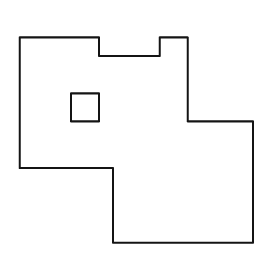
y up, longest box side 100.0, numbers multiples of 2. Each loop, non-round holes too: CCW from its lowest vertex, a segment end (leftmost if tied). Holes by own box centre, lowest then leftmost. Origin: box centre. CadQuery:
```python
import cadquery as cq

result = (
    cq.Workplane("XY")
    .moveTo(-10.0, -44.0)
    .lineTo(50.0, -44.0)
    .lineTo(50.0, 8.0)
    .lineTo(22.0, 8.0)
    .lineTo(22.0, 44.0)
    .lineTo(10.0, 44.0)
    .lineTo(10.0, 36.0)
    .lineTo(-16.0, 36.0)
    .lineTo(-16.0, 44.0)
    .lineTo(-50.0, 44.0)
    .lineTo(-50.0, -12.0)
    .lineTo(-10.0, -12.0)
    .close()
    .moveTo(-28.0, 8.0)
    .lineTo(-16.0, 8.0)
    .lineTo(-16.0, 20.0)
    .lineTo(-28.0, 20.0)
    .close()
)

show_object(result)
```